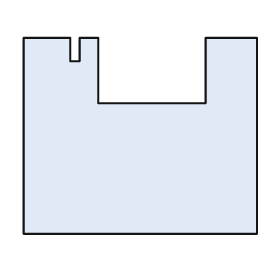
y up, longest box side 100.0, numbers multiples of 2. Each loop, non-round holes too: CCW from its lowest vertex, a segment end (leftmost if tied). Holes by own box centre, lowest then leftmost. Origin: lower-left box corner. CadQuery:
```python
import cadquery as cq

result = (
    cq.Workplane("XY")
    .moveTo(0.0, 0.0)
    .lineTo(100.0, 0.0)
    .lineTo(100.0, 84.0)
    .lineTo(78.0, 84.0)
    .lineTo(78.0, 56.0)
    .lineTo(32.0, 56.0)
    .lineTo(32.0, 84.0)
    .lineTo(24.0, 84.0)
    .lineTo(24.0, 74.0)
    .lineTo(20.0, 74.0)
    .lineTo(20.0, 84.0)
    .lineTo(0.0, 84.0)
    .close()
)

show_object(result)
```